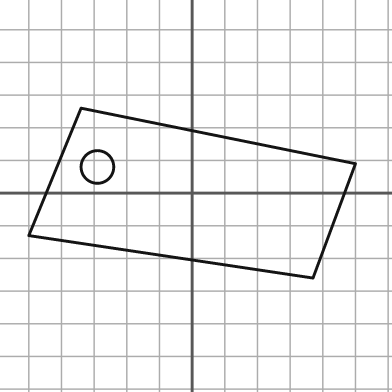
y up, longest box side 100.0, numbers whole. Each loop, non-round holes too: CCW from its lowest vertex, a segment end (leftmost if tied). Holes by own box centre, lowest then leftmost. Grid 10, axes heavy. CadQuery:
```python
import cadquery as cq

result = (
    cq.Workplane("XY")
    .moveTo(37.0, -26.0)
    .lineTo(50.0, 9.0)
    .lineTo(-34.0, 26.0)
    .lineTo(-50.0, -13.0)
    .close()
    .moveTo(-29.0, 8.0)
    .circle(5.0)
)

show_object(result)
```